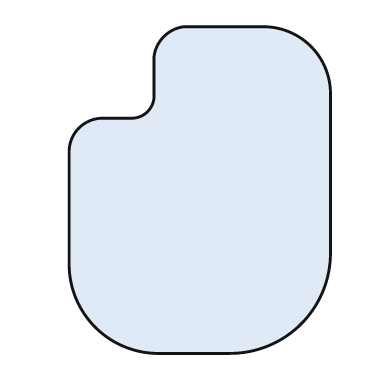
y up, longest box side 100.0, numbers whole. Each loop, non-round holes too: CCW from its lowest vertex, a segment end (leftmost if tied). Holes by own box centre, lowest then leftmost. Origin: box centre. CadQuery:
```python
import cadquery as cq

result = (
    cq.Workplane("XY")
    .moveTo(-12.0, -50.0)
    .lineTo(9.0, -50.0)
    .threePointArc((31.0, -41.0), (40.0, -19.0))
    .lineTo(40.0, 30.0)
    .threePointArc((34.0, 44.0), (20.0, 50.0))
    .lineTo(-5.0, 50.0)
    .threePointArc((-11.0, 47.0), (-14.0, 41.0))
    .lineTo(-14.0, 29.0)
    .threePointArc((-16.0, 24.0), (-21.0, 22.0))
    .lineTo(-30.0, 22.0)
    .threePointArc((-37.0, 19.0), (-40.0, 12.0))
    .lineTo(-40.0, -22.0)
    .threePointArc((-32.0, -42.0), (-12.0, -50.0))
    .close()
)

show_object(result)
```